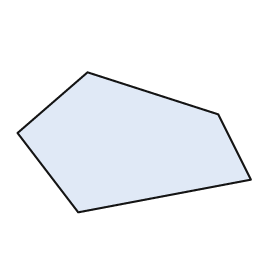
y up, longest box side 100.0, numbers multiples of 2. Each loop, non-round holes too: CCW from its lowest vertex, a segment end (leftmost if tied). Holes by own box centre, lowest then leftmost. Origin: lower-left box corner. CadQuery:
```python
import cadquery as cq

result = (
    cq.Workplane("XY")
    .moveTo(26.0, 0.0)
    .lineTo(100.0, 14.0)
    .lineTo(86.0, 42.0)
    .lineTo(30.0, 60.0)
    .lineTo(0.0, 34.0)
    .close()
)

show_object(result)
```